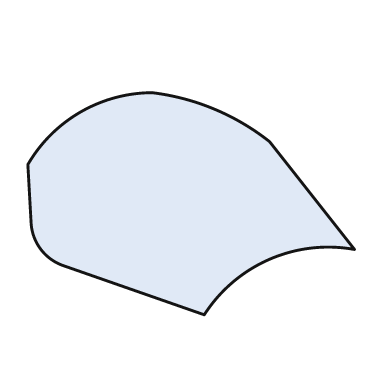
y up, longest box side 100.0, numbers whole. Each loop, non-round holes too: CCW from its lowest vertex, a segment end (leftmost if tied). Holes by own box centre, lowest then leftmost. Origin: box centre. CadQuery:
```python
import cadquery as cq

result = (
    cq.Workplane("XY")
    .moveTo(4.0, -34.0)
    .threePointArc((24.0, -17.0), (50.0, -14.0))
    .lineTo(24.0, 19.0)
    .threePointArc((7.0, 29.0), (-12.0, 34.0))
    .threePointArc((-34.0, 28.0), (-50.0, 12.0))
    .lineTo(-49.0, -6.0)
    .threePointArc((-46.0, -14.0), (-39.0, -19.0))
    .close()
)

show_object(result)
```